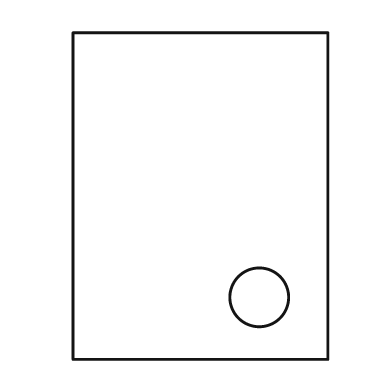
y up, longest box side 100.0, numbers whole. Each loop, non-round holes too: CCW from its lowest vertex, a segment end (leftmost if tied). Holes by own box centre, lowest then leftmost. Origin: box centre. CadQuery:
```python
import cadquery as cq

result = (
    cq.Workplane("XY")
    .moveTo(-39.0, -50.0)
    .lineTo(39.0, -50.0)
    .lineTo(39.0, 50.0)
    .lineTo(-39.0, 50.0)
    .close()
    .moveTo(18.0, -31.0)
    .circle(9.0)
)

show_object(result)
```